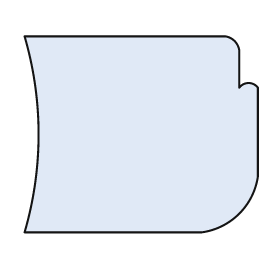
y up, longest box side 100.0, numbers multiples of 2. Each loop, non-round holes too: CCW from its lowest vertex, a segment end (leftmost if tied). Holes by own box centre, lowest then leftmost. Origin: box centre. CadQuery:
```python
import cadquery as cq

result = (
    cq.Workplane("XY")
    .moveTo(-50.0, -42.0)
    .lineTo(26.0, -42.0)
    .threePointArc((42.0, -34.0), (50.0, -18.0))
    .lineTo(50.0, 20.0)
    .threePointArc((46.0, 22.0), (42.0, 20.0))
    .lineTo(42.0, 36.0)
    .threePointArc((40.0, 40.0), (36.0, 42.0))
    .lineTo(-50.0, 42.0)
    .threePointArc((-44.0, 0.0), (-50.0, -42.0))
    .close()
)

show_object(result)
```